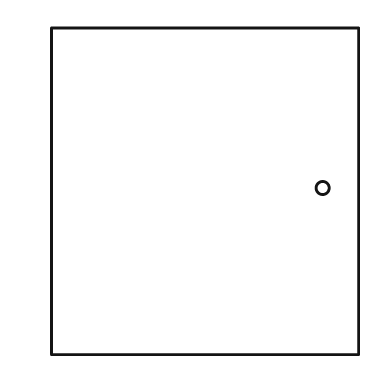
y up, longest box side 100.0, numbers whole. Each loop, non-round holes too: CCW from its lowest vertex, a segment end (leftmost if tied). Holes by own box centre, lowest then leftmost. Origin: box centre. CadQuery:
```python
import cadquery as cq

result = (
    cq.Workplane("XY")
    .moveTo(-47.0, -50.0)
    .lineTo(47.0, -50.0)
    .lineTo(47.0, 50.0)
    .lineTo(-47.0, 50.0)
    .close()
    .moveTo(36.0, 1.0)
    .circle(2.0)
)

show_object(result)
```